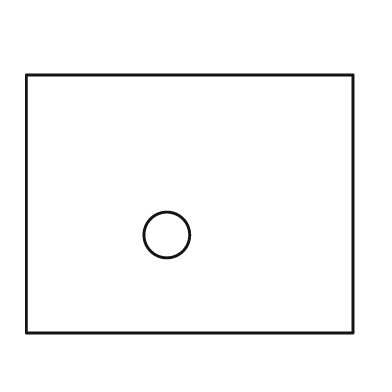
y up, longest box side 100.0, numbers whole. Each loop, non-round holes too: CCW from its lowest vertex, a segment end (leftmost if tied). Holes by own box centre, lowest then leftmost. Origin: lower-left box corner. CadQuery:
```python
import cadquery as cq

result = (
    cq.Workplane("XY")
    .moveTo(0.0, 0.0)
    .lineTo(100.0, 0.0)
    .lineTo(100.0, 79.0)
    .lineTo(0.0, 79.0)
    .close()
    .moveTo(43.0, 30.0)
    .circle(7.0)
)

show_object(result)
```